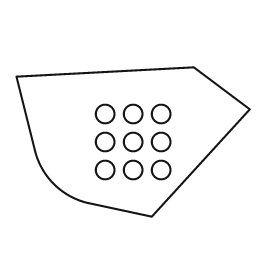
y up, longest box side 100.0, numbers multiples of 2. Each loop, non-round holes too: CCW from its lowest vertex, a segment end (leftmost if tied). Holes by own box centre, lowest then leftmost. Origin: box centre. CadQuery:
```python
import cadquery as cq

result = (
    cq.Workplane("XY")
    .moveTo(8.0, -32.0)
    .lineTo(50.0, 14.0)
    .lineTo(26.0, 32.0)
    .lineTo(-50.0, 28.0)
    .lineTo(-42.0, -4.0)
    .threePointArc((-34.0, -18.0), (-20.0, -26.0))
    .close()
    .moveTo(-12.0, -12.0)
    .circle(4.0)
    .moveTo(0.0, -12.0)
    .circle(4.0)
    .moveTo(12.0, -12.0)
    .circle(4.0)
    .moveTo(-12.0, 0.0)
    .circle(4.0)
    .moveTo(0.0, 0.0)
    .circle(4.0)
    .moveTo(12.0, 0.0)
    .circle(4.0)
    .moveTo(-12.0, 12.0)
    .circle(4.0)
    .moveTo(0.0, 12.0)
    .circle(4.0)
    .moveTo(12.0, 12.0)
    .circle(4.0)
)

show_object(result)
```